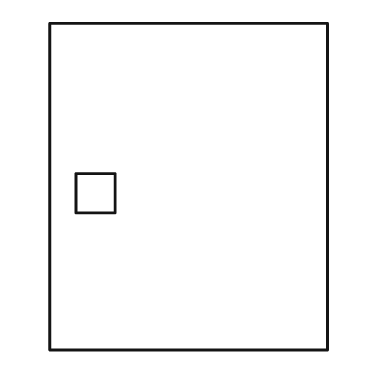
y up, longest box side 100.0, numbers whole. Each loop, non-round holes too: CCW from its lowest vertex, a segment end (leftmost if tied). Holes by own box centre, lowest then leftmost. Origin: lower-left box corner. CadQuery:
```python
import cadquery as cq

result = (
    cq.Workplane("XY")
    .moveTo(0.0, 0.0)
    .lineTo(85.0, 0.0)
    .lineTo(85.0, 100.0)
    .lineTo(0.0, 100.0)
    .close()
    .moveTo(8.0, 42.0)
    .lineTo(20.0, 42.0)
    .lineTo(20.0, 54.0)
    .lineTo(8.0, 54.0)
    .close()
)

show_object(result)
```